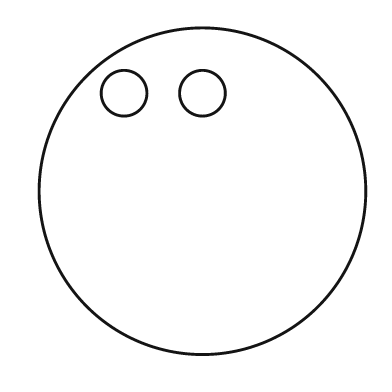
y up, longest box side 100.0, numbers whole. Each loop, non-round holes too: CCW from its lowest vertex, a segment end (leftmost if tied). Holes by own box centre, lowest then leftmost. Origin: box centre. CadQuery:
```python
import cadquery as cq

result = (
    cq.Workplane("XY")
    .moveTo(0.0, 0.0)
    .circle(50.0)
    .moveTo(-24.0, 30.0)
    .circle(7.0)
    .moveTo(0.0, 30.0)
    .circle(7.0)
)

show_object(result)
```